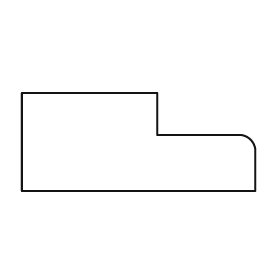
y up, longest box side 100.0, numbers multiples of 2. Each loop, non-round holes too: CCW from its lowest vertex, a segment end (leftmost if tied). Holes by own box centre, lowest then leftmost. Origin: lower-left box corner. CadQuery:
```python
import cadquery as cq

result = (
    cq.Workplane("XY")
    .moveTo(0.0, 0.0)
    .lineTo(100.0, 0.0)
    .lineTo(100.0, 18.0)
    .threePointArc((98.0, 22.0), (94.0, 24.0))
    .lineTo(58.0, 24.0)
    .lineTo(58.0, 42.0)
    .lineTo(0.0, 42.0)
    .close()
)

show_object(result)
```